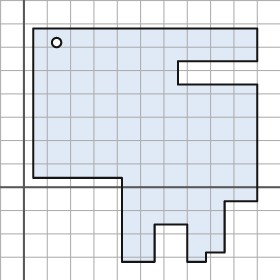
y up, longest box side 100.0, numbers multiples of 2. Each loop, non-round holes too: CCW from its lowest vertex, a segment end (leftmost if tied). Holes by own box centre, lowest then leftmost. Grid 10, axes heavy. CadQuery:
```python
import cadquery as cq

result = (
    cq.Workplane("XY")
    .moveTo(42.0, -32.0)
    .lineTo(56.0, -32.0)
    .lineTo(56.0, -16.0)
    .lineTo(70.0, -16.0)
    .lineTo(70.0, -32.0)
    .lineTo(78.0, -32.0)
    .lineTo(78.0, -28.0)
    .lineTo(86.0, -28.0)
    .lineTo(86.0, -6.0)
    .lineTo(100.0, -6.0)
    .lineTo(100.0, 44.0)
    .lineTo(66.0, 44.0)
    .lineTo(66.0, 54.0)
    .lineTo(100.0, 54.0)
    .lineTo(100.0, 68.0)
    .lineTo(4.0, 68.0)
    .lineTo(4.0, 4.0)
    .lineTo(42.0, 4.0)
    .close()
    .moveTo(14.0, 62.0)
    .circle(2.0)
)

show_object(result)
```